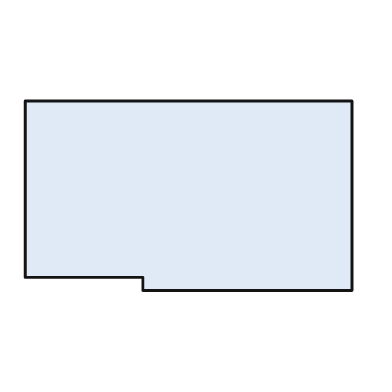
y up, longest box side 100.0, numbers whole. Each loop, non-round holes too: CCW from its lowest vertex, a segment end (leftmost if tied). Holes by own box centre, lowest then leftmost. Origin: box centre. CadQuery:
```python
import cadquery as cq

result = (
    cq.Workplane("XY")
    .moveTo(-14.0, -29.0)
    .lineTo(50.0, -29.0)
    .lineTo(50.0, 29.0)
    .lineTo(-50.0, 29.0)
    .lineTo(-50.0, -25.0)
    .lineTo(-14.0, -25.0)
    .close()
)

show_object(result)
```